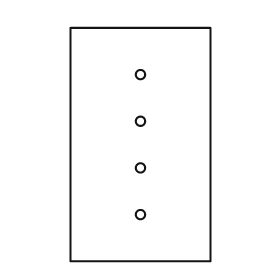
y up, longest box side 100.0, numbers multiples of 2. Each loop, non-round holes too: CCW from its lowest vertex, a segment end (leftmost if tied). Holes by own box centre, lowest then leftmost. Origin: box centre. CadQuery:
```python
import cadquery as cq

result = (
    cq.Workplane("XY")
    .moveTo(-30.0, -50.0)
    .lineTo(30.0, -50.0)
    .lineTo(30.0, 50.0)
    .lineTo(-30.0, 50.0)
    .close()
    .moveTo(0.0, -30.0)
    .circle(2.0)
    .moveTo(0.0, -10.0)
    .circle(2.0)
    .moveTo(0.0, 10.0)
    .circle(2.0)
    .moveTo(0.0, 30.0)
    .circle(2.0)
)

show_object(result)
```